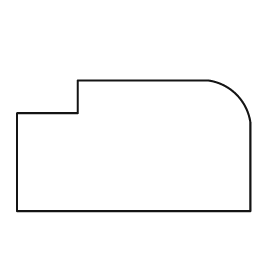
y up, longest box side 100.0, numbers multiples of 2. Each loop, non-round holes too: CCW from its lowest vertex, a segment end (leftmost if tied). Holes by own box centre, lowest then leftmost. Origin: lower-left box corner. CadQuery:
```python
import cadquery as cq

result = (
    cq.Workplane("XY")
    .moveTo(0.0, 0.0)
    .lineTo(100.0, 0.0)
    .lineTo(100.0, 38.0)
    .threePointArc((94.0, 50.0), (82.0, 56.0))
    .lineTo(26.0, 56.0)
    .lineTo(26.0, 42.0)
    .lineTo(0.0, 42.0)
    .close()
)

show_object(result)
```